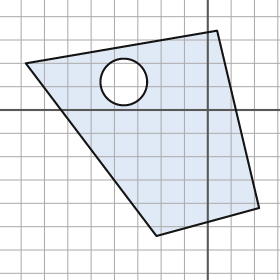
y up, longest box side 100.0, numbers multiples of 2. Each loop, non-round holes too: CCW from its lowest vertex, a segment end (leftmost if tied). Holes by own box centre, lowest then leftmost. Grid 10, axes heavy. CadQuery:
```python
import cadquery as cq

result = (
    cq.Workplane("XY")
    .moveTo(-22.0, -54.0)
    .lineTo(22.0, -42.0)
    .lineTo(4.0, 34.0)
    .lineTo(-78.0, 20.0)
    .close()
    .moveTo(-36.0, 12.0)
    .circle(10.0)
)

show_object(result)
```